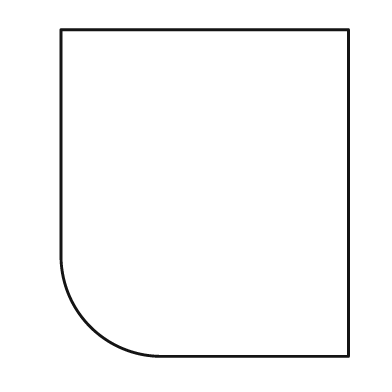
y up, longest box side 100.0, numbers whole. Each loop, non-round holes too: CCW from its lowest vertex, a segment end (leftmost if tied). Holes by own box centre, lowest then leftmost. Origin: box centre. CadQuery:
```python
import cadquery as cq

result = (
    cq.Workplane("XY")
    .moveTo(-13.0, -50.0)
    .lineTo(44.0, -50.0)
    .lineTo(44.0, 50.0)
    .lineTo(-44.0, 50.0)
    .lineTo(-44.0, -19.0)
    .threePointArc((-35.0, -41.0), (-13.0, -50.0))
    .close()
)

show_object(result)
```